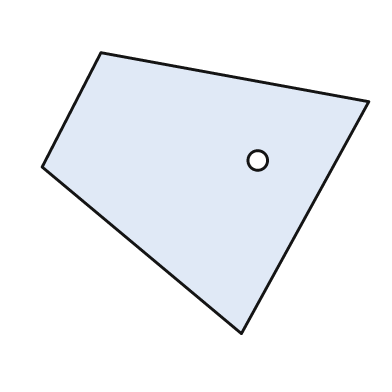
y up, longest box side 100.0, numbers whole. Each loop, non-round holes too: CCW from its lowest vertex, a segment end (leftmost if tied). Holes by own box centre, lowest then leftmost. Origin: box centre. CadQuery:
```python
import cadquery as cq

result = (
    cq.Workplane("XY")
    .moveTo(11.0, -43.0)
    .lineTo(50.0, 28.0)
    .lineTo(-32.0, 43.0)
    .lineTo(-50.0, 8.0)
    .close()
    .moveTo(16.0, 10.0)
    .circle(3.0)
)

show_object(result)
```